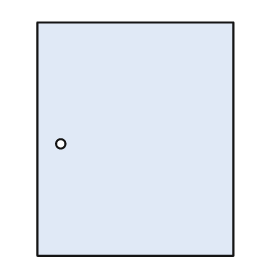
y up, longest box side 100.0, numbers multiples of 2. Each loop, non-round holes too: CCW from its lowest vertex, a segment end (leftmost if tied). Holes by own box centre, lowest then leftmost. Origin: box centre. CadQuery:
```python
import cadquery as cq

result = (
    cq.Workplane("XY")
    .moveTo(-42.0, -50.0)
    .lineTo(42.0, -50.0)
    .lineTo(42.0, 50.0)
    .lineTo(-42.0, 50.0)
    .close()
    .moveTo(-32.0, -2.0)
    .circle(2.0)
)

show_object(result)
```